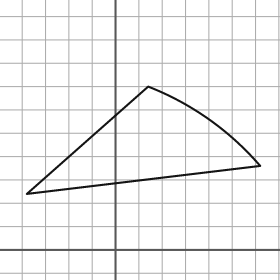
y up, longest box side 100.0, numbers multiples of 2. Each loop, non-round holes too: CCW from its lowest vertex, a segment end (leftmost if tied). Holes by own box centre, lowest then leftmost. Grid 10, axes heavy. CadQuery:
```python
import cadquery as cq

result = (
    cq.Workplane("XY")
    .moveTo(-38.0, 24.0)
    .lineTo(62.0, 36.0)
    .threePointArc((40.0, 56.0), (14.0, 70.0))
    .close()
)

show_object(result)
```